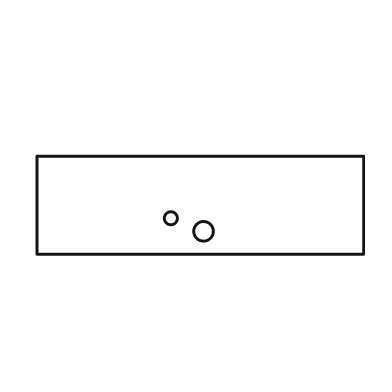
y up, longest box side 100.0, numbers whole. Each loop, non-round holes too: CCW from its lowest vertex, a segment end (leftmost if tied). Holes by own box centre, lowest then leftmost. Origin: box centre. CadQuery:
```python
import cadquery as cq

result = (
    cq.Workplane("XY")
    .moveTo(-50.0, -15.0)
    .lineTo(50.0, -15.0)
    .lineTo(50.0, 15.0)
    .lineTo(-50.0, 15.0)
    .close()
    .moveTo(1.0, -8.0)
    .circle(3.0)
    .moveTo(-9.0, -4.0)
    .circle(2.0)
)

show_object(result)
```